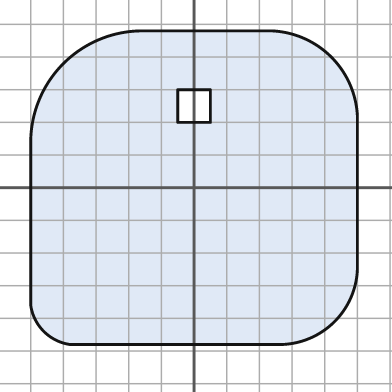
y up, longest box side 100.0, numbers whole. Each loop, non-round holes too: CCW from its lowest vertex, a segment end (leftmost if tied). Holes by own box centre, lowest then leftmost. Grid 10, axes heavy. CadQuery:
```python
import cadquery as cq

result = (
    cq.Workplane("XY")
    .moveTo(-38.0, -48.0)
    .lineTo(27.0, -48.0)
    .threePointArc((43.0, -41.0), (50.0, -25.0))
    .lineTo(50.0, 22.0)
    .threePointArc((42.0, 40.0), (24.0, 48.0))
    .lineTo(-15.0, 48.0)
    .threePointArc((-40.0, 38.0), (-50.0, 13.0))
    .lineTo(-50.0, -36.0)
    .threePointArc((-46.0, -44.0), (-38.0, -48.0))
    .close()
    .moveTo(-5.0, 20.0)
    .lineTo(5.0, 20.0)
    .lineTo(5.0, 30.0)
    .lineTo(-5.0, 30.0)
    .close()
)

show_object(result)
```